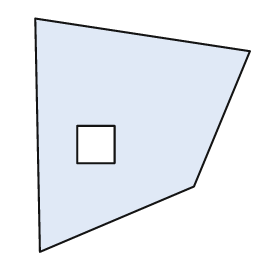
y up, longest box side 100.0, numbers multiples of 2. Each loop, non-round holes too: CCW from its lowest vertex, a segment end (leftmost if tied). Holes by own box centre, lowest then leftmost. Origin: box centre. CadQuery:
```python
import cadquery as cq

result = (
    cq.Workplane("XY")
    .moveTo(-44.0, -50.0)
    .lineTo(22.0, -22.0)
    .lineTo(46.0, 36.0)
    .lineTo(-46.0, 50.0)
    .close()
    .moveTo(-28.0, -12.0)
    .lineTo(-12.0, -12.0)
    .lineTo(-12.0, 4.0)
    .lineTo(-28.0, 4.0)
    .close()
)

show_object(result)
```